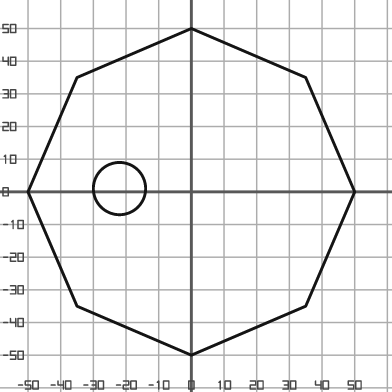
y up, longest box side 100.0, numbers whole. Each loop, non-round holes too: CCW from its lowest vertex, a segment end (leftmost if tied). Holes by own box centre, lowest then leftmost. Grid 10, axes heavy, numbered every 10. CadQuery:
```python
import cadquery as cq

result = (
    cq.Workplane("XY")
    .moveTo(0.0, -50.0)
    .lineTo(35.0, -35.0)
    .lineTo(50.0, 0.0)
    .lineTo(35.0, 35.0)
    .lineTo(0.0, 50.0)
    .lineTo(-35.0, 35.0)
    .lineTo(-50.0, 0.0)
    .lineTo(-35.0, -35.0)
    .close()
    .moveTo(-22.0, 1.0)
    .circle(8.0)
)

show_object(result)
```